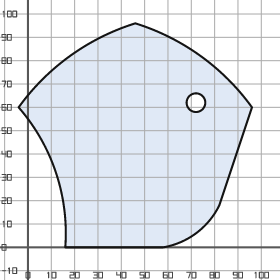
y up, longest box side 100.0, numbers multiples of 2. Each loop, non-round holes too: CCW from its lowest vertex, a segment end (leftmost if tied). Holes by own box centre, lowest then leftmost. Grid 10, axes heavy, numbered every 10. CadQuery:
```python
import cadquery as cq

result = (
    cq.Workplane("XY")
    .moveTo(16.0, 0.0)
    .lineTo(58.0, 0.0)
    .threePointArc((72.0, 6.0), (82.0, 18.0))
    .lineTo(96.0, 60.0)
    .threePointArc((74.0, 82.0), (46.0, 96.0))
    .threePointArc((18.0, 82.0), (-4.0, 60.0))
    .threePointArc((12.0, 32.0), (16.0, 0.0))
    .close()
    .moveTo(72.0, 62.0)
    .circle(4.0)
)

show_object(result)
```